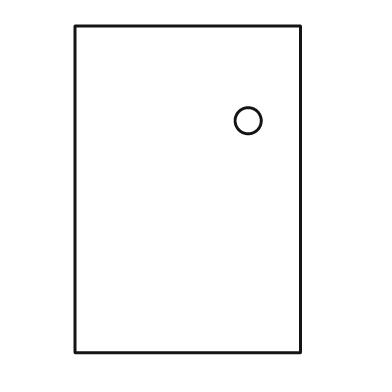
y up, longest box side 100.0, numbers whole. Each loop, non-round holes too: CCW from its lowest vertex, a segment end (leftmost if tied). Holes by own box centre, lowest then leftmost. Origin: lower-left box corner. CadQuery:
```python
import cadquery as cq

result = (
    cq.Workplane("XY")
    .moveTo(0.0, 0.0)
    .lineTo(69.0, 0.0)
    .lineTo(69.0, 100.0)
    .lineTo(0.0, 100.0)
    .close()
    .moveTo(53.0, 71.0)
    .circle(4.0)
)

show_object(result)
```